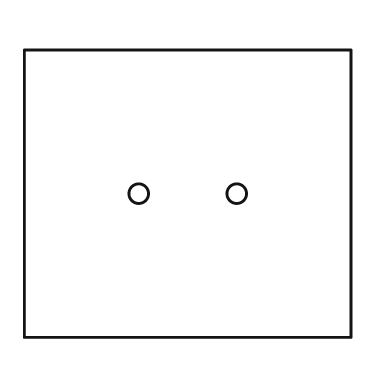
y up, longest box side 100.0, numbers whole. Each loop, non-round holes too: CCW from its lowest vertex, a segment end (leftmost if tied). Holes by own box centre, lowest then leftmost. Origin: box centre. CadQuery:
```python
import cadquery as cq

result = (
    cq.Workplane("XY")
    .moveTo(-50.0, -44.0)
    .lineTo(50.0, -44.0)
    .lineTo(50.0, 44.0)
    .lineTo(-50.0, 44.0)
    .close()
    .moveTo(-15.0, 0.0)
    .circle(3.0)
    .moveTo(15.0, 0.0)
    .circle(3.0)
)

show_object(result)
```